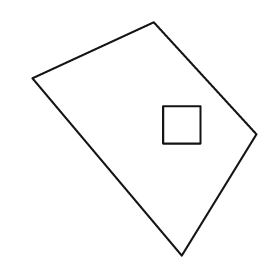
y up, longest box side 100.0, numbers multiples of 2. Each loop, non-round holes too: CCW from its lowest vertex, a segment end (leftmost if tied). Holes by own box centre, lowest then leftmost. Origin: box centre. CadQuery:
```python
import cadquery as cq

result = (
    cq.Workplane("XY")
    .moveTo(16.0, -50.0)
    .lineTo(48.0, 2.0)
    .lineTo(4.0, 50.0)
    .lineTo(-48.0, 26.0)
    .close()
    .moveTo(8.0, -2.0)
    .lineTo(24.0, -2.0)
    .lineTo(24.0, 14.0)
    .lineTo(8.0, 14.0)
    .close()
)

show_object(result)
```